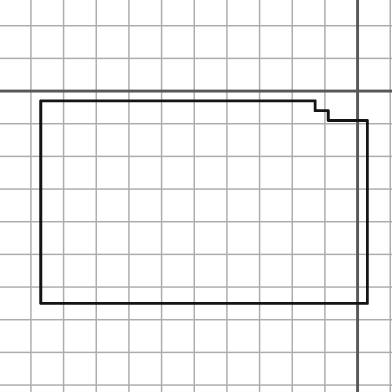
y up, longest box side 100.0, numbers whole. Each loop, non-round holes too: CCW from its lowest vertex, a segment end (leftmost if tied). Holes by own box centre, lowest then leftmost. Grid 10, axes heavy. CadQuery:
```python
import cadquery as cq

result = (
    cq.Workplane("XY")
    .moveTo(-97.0, -65.0)
    .lineTo(3.0, -65.0)
    .lineTo(3.0, -9.0)
    .lineTo(-9.0, -9.0)
    .lineTo(-9.0, -6.0)
    .lineTo(-13.0, -6.0)
    .lineTo(-13.0, -3.0)
    .lineTo(-97.0, -3.0)
    .close()
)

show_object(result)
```